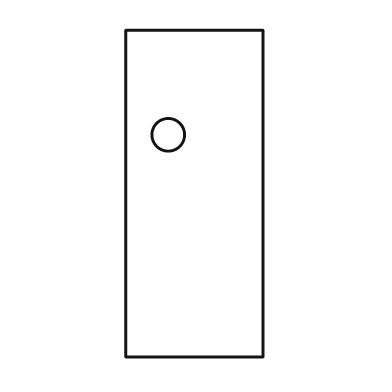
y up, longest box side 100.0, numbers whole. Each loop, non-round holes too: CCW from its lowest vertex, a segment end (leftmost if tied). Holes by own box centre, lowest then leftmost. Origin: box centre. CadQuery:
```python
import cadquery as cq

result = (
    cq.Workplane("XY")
    .moveTo(-21.0, -50.0)
    .lineTo(21.0, -50.0)
    .lineTo(21.0, 50.0)
    .lineTo(-21.0, 50.0)
    .close()
    .moveTo(-8.0, 18.0)
    .circle(5.0)
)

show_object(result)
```